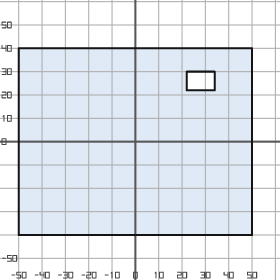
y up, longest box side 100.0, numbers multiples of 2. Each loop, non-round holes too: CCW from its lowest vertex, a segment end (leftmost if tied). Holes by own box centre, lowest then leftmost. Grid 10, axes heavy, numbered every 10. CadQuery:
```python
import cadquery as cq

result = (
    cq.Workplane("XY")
    .moveTo(-50.0, -40.0)
    .lineTo(50.0, -40.0)
    .lineTo(50.0, 40.0)
    .lineTo(-50.0, 40.0)
    .close()
    .moveTo(22.0, 22.0)
    .lineTo(34.0, 22.0)
    .lineTo(34.0, 30.0)
    .lineTo(22.0, 30.0)
    .close()
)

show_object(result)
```